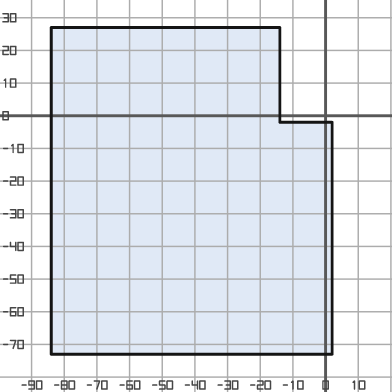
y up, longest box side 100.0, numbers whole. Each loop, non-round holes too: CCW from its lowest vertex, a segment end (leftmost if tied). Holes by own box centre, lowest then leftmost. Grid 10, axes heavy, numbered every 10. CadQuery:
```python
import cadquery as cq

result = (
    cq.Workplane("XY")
    .moveTo(-84.0, -73.0)
    .lineTo(2.0, -73.0)
    .lineTo(2.0, -2.0)
    .lineTo(-14.0, -2.0)
    .lineTo(-14.0, 27.0)
    .lineTo(-84.0, 27.0)
    .close()
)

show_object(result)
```